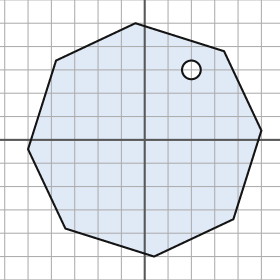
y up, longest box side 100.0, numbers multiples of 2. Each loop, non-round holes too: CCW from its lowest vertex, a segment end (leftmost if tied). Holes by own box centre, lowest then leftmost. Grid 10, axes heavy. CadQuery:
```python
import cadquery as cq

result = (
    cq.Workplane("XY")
    .moveTo(4.0, -50.0)
    .lineTo(38.0, -34.0)
    .lineTo(50.0, 4.0)
    .lineTo(34.0, 38.0)
    .lineTo(-4.0, 50.0)
    .lineTo(-38.0, 34.0)
    .lineTo(-50.0, -4.0)
    .lineTo(-34.0, -38.0)
    .close()
    .moveTo(20.0, 30.0)
    .circle(4.0)
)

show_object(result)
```